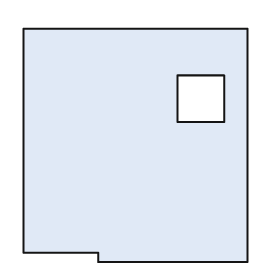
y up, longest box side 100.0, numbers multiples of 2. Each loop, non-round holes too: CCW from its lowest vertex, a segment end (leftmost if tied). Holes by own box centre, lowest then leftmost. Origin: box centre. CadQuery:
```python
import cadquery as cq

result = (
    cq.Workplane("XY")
    .moveTo(-16.0, -50.0)
    .lineTo(48.0, -50.0)
    .lineTo(48.0, 50.0)
    .lineTo(-48.0, 50.0)
    .lineTo(-48.0, -46.0)
    .lineTo(-16.0, -46.0)
    .close()
    .moveTo(18.0, 10.0)
    .lineTo(38.0, 10.0)
    .lineTo(38.0, 30.0)
    .lineTo(18.0, 30.0)
    .close()
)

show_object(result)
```